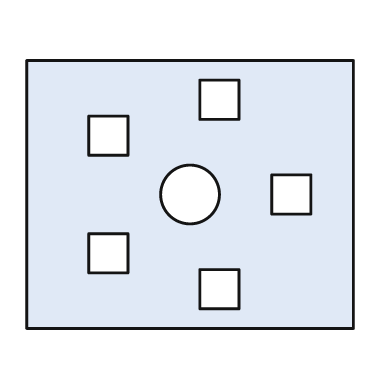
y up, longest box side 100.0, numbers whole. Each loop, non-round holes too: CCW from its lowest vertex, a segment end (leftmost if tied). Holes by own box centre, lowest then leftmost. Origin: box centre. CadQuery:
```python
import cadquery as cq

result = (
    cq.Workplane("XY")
    .moveTo(-50.0, -41.0)
    .lineTo(50.0, -41.0)
    .lineTo(50.0, 41.0)
    .lineTo(-50.0, 41.0)
    .close()
    .moveTo(3.0, -35.0)
    .lineTo(15.0, -35.0)
    .lineTo(15.0, -23.0)
    .lineTo(3.0, -23.0)
    .close()
    .moveTo(-31.0, -24.0)
    .lineTo(-19.0, -24.0)
    .lineTo(-19.0, -12.0)
    .lineTo(-31.0, -12.0)
    .close()
    .moveTo(0.0, 0.0)
    .circle(9.0)
    .moveTo(25.0, -6.0)
    .lineTo(37.0, -6.0)
    .lineTo(37.0, 6.0)
    .lineTo(25.0, 6.0)
    .close()
    .moveTo(-31.0, 12.0)
    .lineTo(-19.0, 12.0)
    .lineTo(-19.0, 24.0)
    .lineTo(-31.0, 24.0)
    .close()
    .moveTo(3.0, 23.0)
    .lineTo(15.0, 23.0)
    .lineTo(15.0, 35.0)
    .lineTo(3.0, 35.0)
    .close()
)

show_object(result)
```